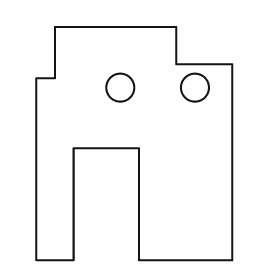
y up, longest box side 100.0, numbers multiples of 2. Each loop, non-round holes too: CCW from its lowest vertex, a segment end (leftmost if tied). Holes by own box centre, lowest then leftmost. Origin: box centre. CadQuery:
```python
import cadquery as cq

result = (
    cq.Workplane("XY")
    .moveTo(-42.0, -50.0)
    .lineTo(-26.0, -50.0)
    .lineTo(-26.0, -2.0)
    .lineTo(2.0, -2.0)
    .lineTo(2.0, -50.0)
    .lineTo(42.0, -50.0)
    .lineTo(42.0, 34.0)
    .lineTo(18.0, 34.0)
    .lineTo(18.0, 50.0)
    .lineTo(-34.0, 50.0)
    .lineTo(-34.0, 28.0)
    .lineTo(-42.0, 28.0)
    .close()
    .moveTo(-6.0, 24.0)
    .circle(6.0)
    .moveTo(26.0, 24.0)
    .circle(6.0)
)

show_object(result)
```